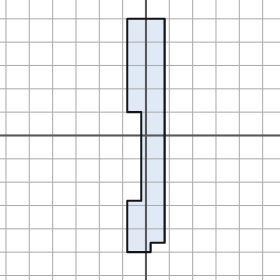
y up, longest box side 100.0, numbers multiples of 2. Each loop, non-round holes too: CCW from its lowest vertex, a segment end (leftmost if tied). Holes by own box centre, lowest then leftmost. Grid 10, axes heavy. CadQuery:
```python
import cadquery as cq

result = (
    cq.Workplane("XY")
    .moveTo(-8.0, -50.0)
    .lineTo(2.0, -50.0)
    .lineTo(2.0, -46.0)
    .lineTo(8.0, -46.0)
    .lineTo(8.0, 50.0)
    .lineTo(-8.0, 50.0)
    .lineTo(-8.0, 10.0)
    .lineTo(-2.0, 10.0)
    .lineTo(-2.0, -28.0)
    .lineTo(-8.0, -28.0)
    .close()
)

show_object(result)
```